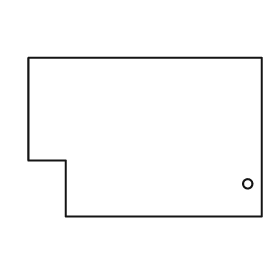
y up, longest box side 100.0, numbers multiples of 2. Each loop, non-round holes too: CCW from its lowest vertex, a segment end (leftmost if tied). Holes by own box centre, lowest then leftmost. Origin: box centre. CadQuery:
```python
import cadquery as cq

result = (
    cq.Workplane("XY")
    .moveTo(-34.0, -34.0)
    .lineTo(50.0, -34.0)
    .lineTo(50.0, 34.0)
    .lineTo(-50.0, 34.0)
    .lineTo(-50.0, -10.0)
    .lineTo(-34.0, -10.0)
    .close()
    .moveTo(44.0, -20.0)
    .circle(2.0)
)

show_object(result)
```